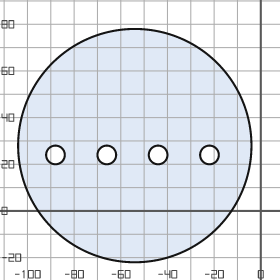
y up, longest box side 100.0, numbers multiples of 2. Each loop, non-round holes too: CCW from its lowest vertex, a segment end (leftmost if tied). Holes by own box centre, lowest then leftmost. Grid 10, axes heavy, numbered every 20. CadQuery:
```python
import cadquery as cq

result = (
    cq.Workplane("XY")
    .moveTo(-54.0, 28.0)
    .circle(50.0)
    .moveTo(-88.0, 24.0)
    .circle(4.0)
    .moveTo(-66.0, 24.0)
    .circle(4.0)
    .moveTo(-44.0, 24.0)
    .circle(4.0)
    .moveTo(-22.0, 24.0)
    .circle(4.0)
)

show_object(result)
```